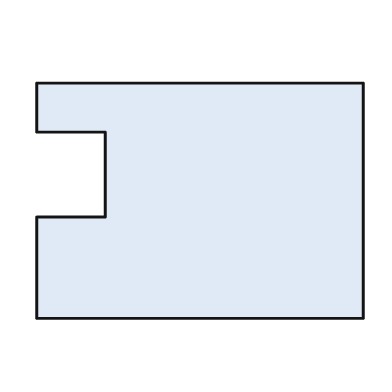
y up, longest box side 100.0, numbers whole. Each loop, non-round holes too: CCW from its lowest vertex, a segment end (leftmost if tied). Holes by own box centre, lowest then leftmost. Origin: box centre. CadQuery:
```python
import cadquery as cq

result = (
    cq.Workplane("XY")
    .moveTo(-50.0, -36.0)
    .lineTo(50.0, -36.0)
    .lineTo(50.0, 36.0)
    .lineTo(-50.0, 36.0)
    .lineTo(-50.0, 21.0)
    .lineTo(-29.0, 21.0)
    .lineTo(-29.0, -5.0)
    .lineTo(-50.0, -5.0)
    .close()
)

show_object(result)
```